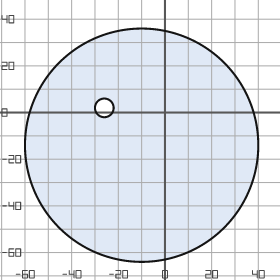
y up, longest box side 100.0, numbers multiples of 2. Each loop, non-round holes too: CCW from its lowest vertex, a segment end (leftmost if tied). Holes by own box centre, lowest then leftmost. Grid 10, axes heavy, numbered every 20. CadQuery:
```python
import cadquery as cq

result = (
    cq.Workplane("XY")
    .moveTo(-10.0, -14.0)
    .circle(50.0)
    .moveTo(-26.0, 2.0)
    .circle(4.0)
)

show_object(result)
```